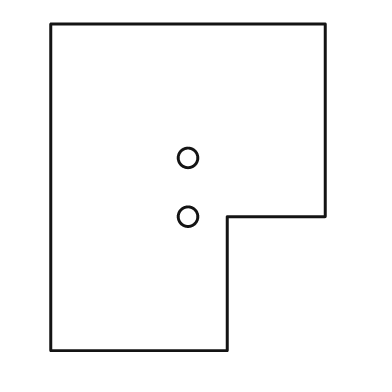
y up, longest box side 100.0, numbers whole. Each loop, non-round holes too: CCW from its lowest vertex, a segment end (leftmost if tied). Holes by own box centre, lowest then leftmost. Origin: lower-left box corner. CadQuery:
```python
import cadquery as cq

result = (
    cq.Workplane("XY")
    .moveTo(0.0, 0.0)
    .lineTo(54.0, 0.0)
    .lineTo(54.0, 41.0)
    .lineTo(84.0, 41.0)
    .lineTo(84.0, 100.0)
    .lineTo(0.0, 100.0)
    .close()
    .moveTo(42.0, 41.0)
    .circle(3.0)
    .moveTo(42.0, 59.0)
    .circle(3.0)
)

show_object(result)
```